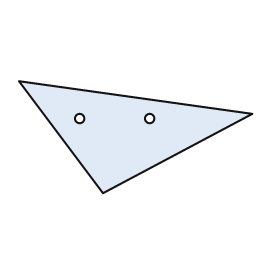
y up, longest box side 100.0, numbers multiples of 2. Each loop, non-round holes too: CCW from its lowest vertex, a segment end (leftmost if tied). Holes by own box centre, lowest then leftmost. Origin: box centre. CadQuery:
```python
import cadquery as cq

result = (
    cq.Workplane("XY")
    .moveTo(-14.0, -24.0)
    .lineTo(50.0, 10.0)
    .lineTo(-50.0, 24.0)
    .close()
    .moveTo(-24.0, 8.0)
    .circle(2.0)
    .moveTo(6.0, 8.0)
    .circle(2.0)
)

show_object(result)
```